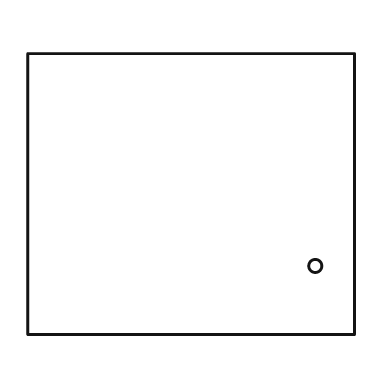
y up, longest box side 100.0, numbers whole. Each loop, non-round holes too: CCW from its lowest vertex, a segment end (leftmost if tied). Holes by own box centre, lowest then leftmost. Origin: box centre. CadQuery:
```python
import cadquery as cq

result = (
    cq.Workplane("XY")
    .moveTo(-50.0, -43.0)
    .lineTo(50.0, -43.0)
    .lineTo(50.0, 43.0)
    .lineTo(-50.0, 43.0)
    .close()
    .moveTo(38.0, -22.0)
    .circle(2.0)
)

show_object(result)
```